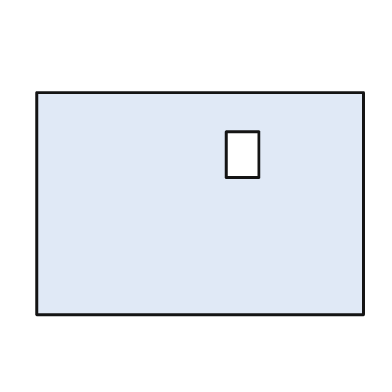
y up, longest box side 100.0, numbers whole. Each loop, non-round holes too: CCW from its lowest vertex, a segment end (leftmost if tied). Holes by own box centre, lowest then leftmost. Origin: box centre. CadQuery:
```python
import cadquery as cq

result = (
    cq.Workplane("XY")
    .moveTo(-50.0, -34.0)
    .lineTo(50.0, -34.0)
    .lineTo(50.0, 34.0)
    .lineTo(-50.0, 34.0)
    .close()
    .moveTo(8.0, 8.0)
    .lineTo(18.0, 8.0)
    .lineTo(18.0, 22.0)
    .lineTo(8.0, 22.0)
    .close()
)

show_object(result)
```